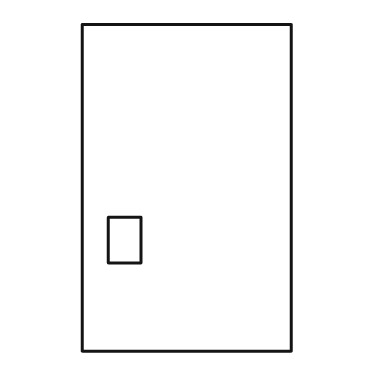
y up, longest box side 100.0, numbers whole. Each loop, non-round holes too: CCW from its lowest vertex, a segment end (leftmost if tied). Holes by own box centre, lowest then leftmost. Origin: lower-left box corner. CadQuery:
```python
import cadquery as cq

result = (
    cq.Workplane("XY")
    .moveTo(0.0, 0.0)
    .lineTo(64.0, 0.0)
    .lineTo(64.0, 100.0)
    .lineTo(0.0, 100.0)
    .close()
    .moveTo(8.0, 27.0)
    .lineTo(18.0, 27.0)
    .lineTo(18.0, 41.0)
    .lineTo(8.0, 41.0)
    .close()
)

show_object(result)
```